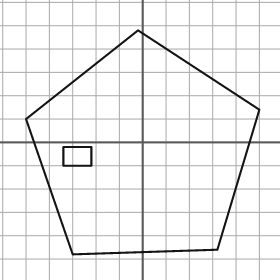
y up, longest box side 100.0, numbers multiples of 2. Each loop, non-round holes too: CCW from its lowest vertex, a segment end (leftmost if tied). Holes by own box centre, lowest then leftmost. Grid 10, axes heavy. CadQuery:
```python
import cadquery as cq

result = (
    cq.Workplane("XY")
    .moveTo(-30.0, -48.0)
    .lineTo(32.0, -46.0)
    .lineTo(50.0, 14.0)
    .lineTo(-2.0, 48.0)
    .lineTo(-50.0, 10.0)
    .close()
    .moveTo(-34.0, -10.0)
    .lineTo(-22.0, -10.0)
    .lineTo(-22.0, -2.0)
    .lineTo(-34.0, -2.0)
    .close()
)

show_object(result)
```